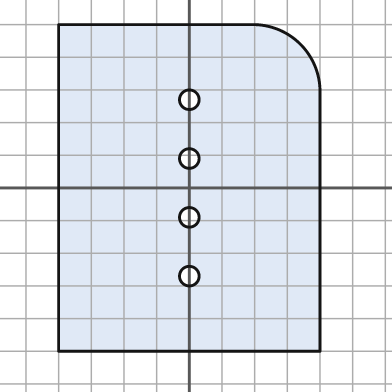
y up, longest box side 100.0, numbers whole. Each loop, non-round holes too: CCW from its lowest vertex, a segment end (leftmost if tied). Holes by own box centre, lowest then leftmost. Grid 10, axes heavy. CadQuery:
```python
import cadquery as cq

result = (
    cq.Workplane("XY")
    .moveTo(-40.0, -50.0)
    .lineTo(40.0, -50.0)
    .lineTo(40.0, 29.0)
    .threePointArc((34.0, 44.0), (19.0, 50.0))
    .lineTo(-40.0, 50.0)
    .close()
    .moveTo(0.0, -27.0)
    .circle(3.0)
    .moveTo(0.0, -9.0)
    .circle(3.0)
    .moveTo(0.0, 9.0)
    .circle(3.0)
    .moveTo(0.0, 27.0)
    .circle(3.0)
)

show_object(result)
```